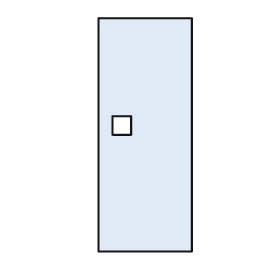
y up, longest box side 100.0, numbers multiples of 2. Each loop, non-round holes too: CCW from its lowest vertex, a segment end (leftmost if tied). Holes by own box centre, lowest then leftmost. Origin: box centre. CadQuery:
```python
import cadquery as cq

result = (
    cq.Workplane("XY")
    .moveTo(-20.0, -50.0)
    .lineTo(20.0, -50.0)
    .lineTo(20.0, 50.0)
    .lineTo(-20.0, 50.0)
    .close()
    .moveTo(-14.0, 0.0)
    .lineTo(-6.0, 0.0)
    .lineTo(-6.0, 8.0)
    .lineTo(-14.0, 8.0)
    .close()
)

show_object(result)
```